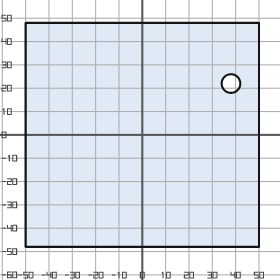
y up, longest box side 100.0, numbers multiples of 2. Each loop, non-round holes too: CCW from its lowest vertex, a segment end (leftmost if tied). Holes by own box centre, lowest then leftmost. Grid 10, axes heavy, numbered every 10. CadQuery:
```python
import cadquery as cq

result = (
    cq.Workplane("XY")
    .moveTo(-50.0, -48.0)
    .lineTo(50.0, -48.0)
    .lineTo(50.0, 48.0)
    .lineTo(-50.0, 48.0)
    .close()
    .moveTo(38.0, 22.0)
    .circle(4.0)
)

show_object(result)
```